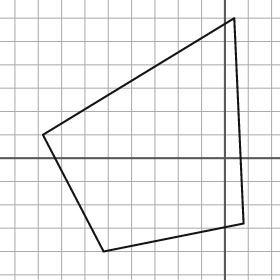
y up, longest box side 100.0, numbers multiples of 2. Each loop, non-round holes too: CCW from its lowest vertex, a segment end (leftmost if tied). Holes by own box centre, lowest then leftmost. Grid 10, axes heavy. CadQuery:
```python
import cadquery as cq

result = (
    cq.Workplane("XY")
    .moveTo(-52.0, -40.0)
    .lineTo(8.0, -28.0)
    .lineTo(4.0, 60.0)
    .lineTo(-78.0, 10.0)
    .close()
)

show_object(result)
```